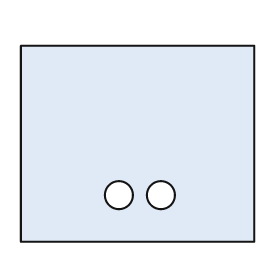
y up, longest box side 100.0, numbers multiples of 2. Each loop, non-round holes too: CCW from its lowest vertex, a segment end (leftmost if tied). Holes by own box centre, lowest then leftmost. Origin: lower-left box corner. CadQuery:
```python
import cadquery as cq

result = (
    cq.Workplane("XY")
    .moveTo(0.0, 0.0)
    .lineTo(100.0, 0.0)
    .lineTo(100.0, 84.0)
    .lineTo(0.0, 84.0)
    .close()
    .moveTo(42.0, 20.0)
    .circle(6.0)
    .moveTo(60.0, 20.0)
    .circle(6.0)
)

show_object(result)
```